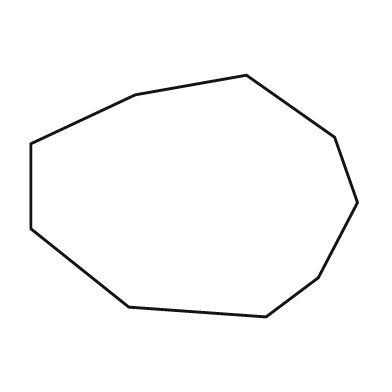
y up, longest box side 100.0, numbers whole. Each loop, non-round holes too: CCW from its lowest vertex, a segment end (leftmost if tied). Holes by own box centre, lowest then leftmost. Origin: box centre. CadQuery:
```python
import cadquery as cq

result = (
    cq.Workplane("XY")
    .moveTo(22.0, -37.0)
    .lineTo(38.0, -25.0)
    .lineTo(50.0, -2.0)
    .lineTo(43.0, 18.0)
    .lineTo(16.0, 37.0)
    .lineTo(-18.0, 31.0)
    .lineTo(-50.0, 16.0)
    .lineTo(-50.0, -10.0)
    .lineTo(-20.0, -34.0)
    .close()
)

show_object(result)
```